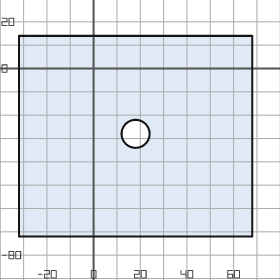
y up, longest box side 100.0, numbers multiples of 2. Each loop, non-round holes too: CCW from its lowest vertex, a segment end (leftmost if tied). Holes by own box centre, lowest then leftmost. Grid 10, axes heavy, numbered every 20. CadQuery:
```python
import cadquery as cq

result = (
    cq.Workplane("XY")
    .moveTo(-32.0, -72.0)
    .lineTo(68.0, -72.0)
    .lineTo(68.0, 14.0)
    .lineTo(-32.0, 14.0)
    .close()
    .moveTo(18.0, -28.0)
    .circle(6.0)
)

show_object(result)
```